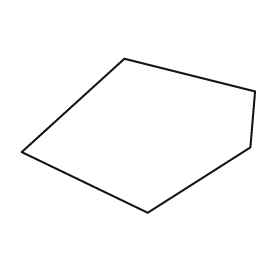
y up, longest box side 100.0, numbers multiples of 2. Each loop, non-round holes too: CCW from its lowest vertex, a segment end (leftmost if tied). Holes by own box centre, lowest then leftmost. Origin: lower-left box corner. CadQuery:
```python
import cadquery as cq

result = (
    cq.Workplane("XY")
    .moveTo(54.0, 0.0)
    .lineTo(98.0, 28.0)
    .lineTo(100.0, 52.0)
    .lineTo(44.0, 66.0)
    .lineTo(0.0, 26.0)
    .close()
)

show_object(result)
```